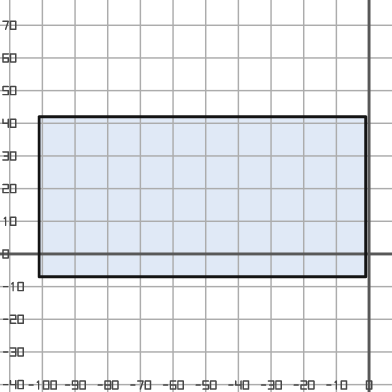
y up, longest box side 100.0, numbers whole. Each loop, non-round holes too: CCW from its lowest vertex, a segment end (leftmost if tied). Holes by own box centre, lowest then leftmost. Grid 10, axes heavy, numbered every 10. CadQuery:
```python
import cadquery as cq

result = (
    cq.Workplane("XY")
    .moveTo(-101.0, -7.0)
    .lineTo(-1.0, -7.0)
    .lineTo(-1.0, 42.0)
    .lineTo(-101.0, 42.0)
    .close()
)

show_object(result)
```